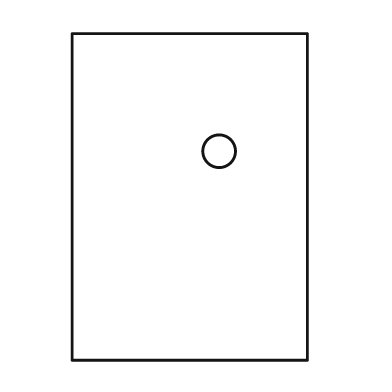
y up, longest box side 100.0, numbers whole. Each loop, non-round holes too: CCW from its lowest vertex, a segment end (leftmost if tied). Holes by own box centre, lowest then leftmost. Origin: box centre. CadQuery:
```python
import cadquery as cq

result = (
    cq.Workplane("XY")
    .moveTo(-36.0, -50.0)
    .lineTo(36.0, -50.0)
    .lineTo(36.0, 50.0)
    .lineTo(-36.0, 50.0)
    .close()
    .moveTo(9.0, 14.0)
    .circle(5.0)
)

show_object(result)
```